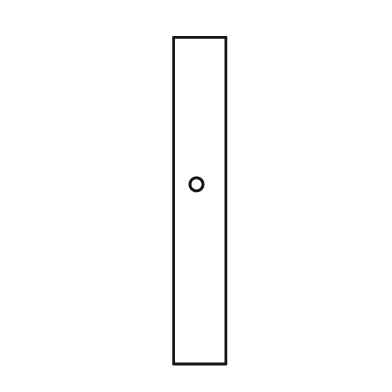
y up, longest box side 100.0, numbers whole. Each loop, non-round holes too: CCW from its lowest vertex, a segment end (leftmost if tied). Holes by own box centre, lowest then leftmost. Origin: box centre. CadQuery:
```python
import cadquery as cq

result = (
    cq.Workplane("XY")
    .moveTo(-8.0, -50.0)
    .lineTo(8.0, -50.0)
    .lineTo(8.0, 50.0)
    .lineTo(-8.0, 50.0)
    .close()
    .moveTo(-1.0, 5.0)
    .circle(2.0)
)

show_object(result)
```